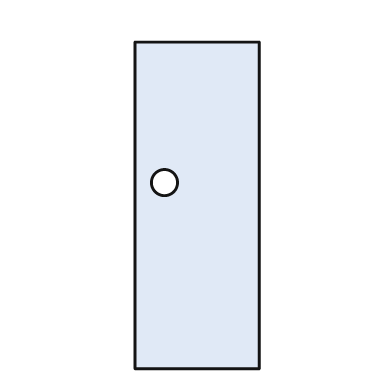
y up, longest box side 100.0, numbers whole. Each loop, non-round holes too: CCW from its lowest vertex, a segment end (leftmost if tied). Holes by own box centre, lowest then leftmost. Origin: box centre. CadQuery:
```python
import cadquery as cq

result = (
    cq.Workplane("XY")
    .moveTo(-19.0, -50.0)
    .lineTo(19.0, -50.0)
    .lineTo(19.0, 50.0)
    .lineTo(-19.0, 50.0)
    .close()
    .moveTo(-10.0, 7.0)
    .circle(4.0)
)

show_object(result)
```